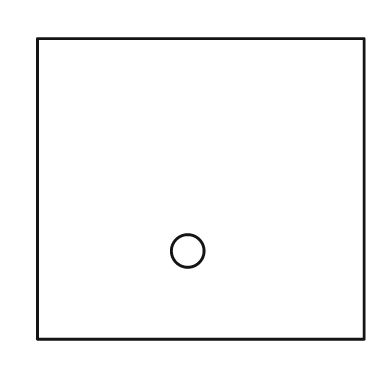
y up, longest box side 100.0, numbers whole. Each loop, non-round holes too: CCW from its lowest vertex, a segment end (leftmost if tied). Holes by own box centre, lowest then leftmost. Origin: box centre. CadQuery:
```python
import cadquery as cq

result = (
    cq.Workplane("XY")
    .moveTo(-50.0, -46.0)
    .lineTo(50.0, -46.0)
    .lineTo(50.0, 46.0)
    .lineTo(-50.0, 46.0)
    .close()
    .moveTo(-4.0, -19.0)
    .circle(5.0)
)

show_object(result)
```